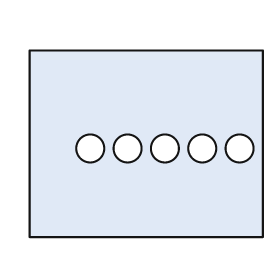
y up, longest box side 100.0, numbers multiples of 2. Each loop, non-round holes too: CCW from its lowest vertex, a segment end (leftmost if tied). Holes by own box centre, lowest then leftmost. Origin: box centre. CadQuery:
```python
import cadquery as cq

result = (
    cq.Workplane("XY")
    .moveTo(-50.0, -40.0)
    .lineTo(50.0, -40.0)
    .lineTo(50.0, 40.0)
    .lineTo(-50.0, 40.0)
    .close()
    .moveTo(-24.0, -2.0)
    .circle(6.0)
    .moveTo(-8.0, -2.0)
    .circle(6.0)
    .moveTo(8.0, -2.0)
    .circle(6.0)
    .moveTo(24.0, -2.0)
    .circle(6.0)
    .moveTo(40.0, -2.0)
    .circle(6.0)
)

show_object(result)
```